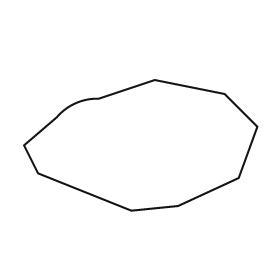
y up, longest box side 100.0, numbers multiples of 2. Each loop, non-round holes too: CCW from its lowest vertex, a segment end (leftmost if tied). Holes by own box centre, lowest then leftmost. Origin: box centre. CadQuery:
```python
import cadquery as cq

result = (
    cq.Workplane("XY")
    .moveTo(-4.0, -28.0)
    .lineTo(16.0, -26.0)
    .lineTo(42.0, -14.0)
    .lineTo(50.0, 8.0)
    .lineTo(36.0, 22.0)
    .lineTo(6.0, 28.0)
    .lineTo(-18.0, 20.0)
    .threePointArc((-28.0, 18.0), (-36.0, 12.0))
    .lineTo(-50.0, 0.0)
    .lineTo(-44.0, -12.0)
    .close()
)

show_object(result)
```